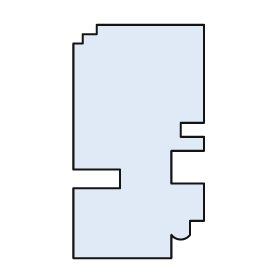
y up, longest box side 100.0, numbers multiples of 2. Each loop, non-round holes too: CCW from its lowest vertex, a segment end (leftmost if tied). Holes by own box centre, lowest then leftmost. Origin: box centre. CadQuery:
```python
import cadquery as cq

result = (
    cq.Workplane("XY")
    .moveTo(-28.0, -50.0)
    .lineTo(14.0, -50.0)
    .lineTo(14.0, -40.0)
    .threePointArc((18.0, -42.0), (22.0, -40.0))
    .lineTo(22.0, -34.0)
    .lineTo(28.0, -34.0)
    .lineTo(28.0, -18.0)
    .lineTo(14.0, -18.0)
    .lineTo(14.0, -4.0)
    .lineTo(28.0, -4.0)
    .lineTo(28.0, 2.0)
    .lineTo(18.0, 2.0)
    .lineTo(18.0, 8.0)
    .lineTo(28.0, 8.0)
    .lineTo(28.0, 50.0)
    .lineTo(-18.0, 50.0)
    .lineTo(-18.0, 46.0)
    .lineTo(-24.0, 46.0)
    .lineTo(-24.0, 42.0)
    .lineTo(-28.0, 42.0)
    .lineTo(-28.0, -12.0)
    .lineTo(-8.0, -12.0)
    .lineTo(-8.0, -20.0)
    .lineTo(-28.0, -20.0)
    .close()
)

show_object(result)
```